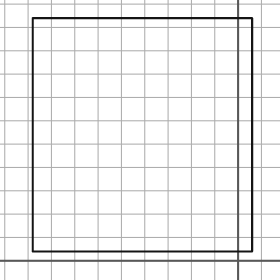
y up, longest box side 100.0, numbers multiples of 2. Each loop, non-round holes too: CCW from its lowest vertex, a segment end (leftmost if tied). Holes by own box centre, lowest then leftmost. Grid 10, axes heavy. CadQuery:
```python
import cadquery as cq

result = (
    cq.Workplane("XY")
    .moveTo(-88.0, 4.0)
    .lineTo(6.0, 4.0)
    .lineTo(6.0, 104.0)
    .lineTo(-88.0, 104.0)
    .close()
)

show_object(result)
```